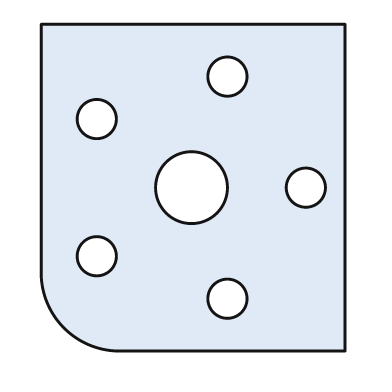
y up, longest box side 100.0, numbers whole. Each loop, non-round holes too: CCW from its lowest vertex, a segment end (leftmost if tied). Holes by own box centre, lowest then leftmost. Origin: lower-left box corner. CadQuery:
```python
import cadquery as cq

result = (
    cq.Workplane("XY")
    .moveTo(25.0, 0.0)
    .lineTo(93.0, 0.0)
    .lineTo(93.0, 100.0)
    .lineTo(0.0, 100.0)
    .lineTo(0.0, 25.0)
    .threePointArc((7.0, 7.0), (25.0, 0.0))
    .close()
    .moveTo(57.0, 16.0)
    .circle(6.0)
    .moveTo(17.0, 29.0)
    .circle(6.0)
    .moveTo(46.0, 50.0)
    .circle(11.0)
    .moveTo(81.0, 50.0)
    .circle(6.0)
    .moveTo(17.0, 71.0)
    .circle(6.0)
    .moveTo(57.0, 84.0)
    .circle(6.0)
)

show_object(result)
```